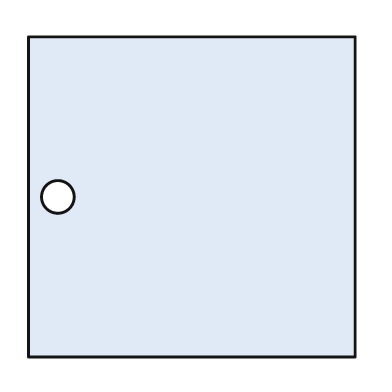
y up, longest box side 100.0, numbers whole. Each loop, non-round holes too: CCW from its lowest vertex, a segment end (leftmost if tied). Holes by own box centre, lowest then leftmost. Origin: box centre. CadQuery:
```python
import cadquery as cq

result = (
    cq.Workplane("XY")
    .moveTo(-50.0, -49.0)
    .lineTo(50.0, -49.0)
    .lineTo(50.0, 49.0)
    .lineTo(-50.0, 49.0)
    .close()
    .moveTo(-41.0, 0.0)
    .circle(5.0)
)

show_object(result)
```